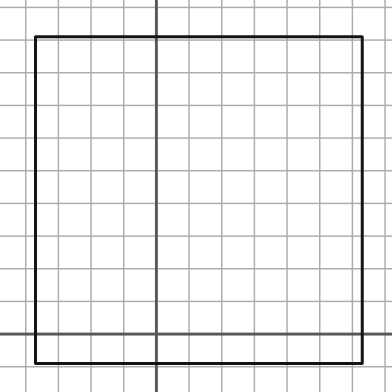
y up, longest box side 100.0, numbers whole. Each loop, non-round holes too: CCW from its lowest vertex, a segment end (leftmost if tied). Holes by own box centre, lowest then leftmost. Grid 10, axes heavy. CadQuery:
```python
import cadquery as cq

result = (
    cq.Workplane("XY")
    .moveTo(-37.0, -9.0)
    .lineTo(63.0, -9.0)
    .lineTo(63.0, 91.0)
    .lineTo(-37.0, 91.0)
    .close()
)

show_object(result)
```